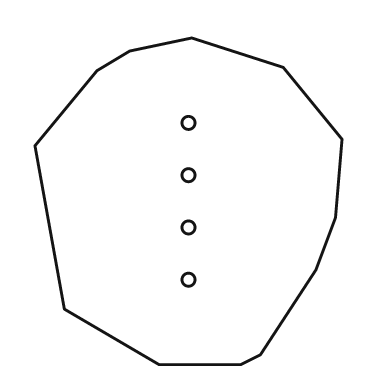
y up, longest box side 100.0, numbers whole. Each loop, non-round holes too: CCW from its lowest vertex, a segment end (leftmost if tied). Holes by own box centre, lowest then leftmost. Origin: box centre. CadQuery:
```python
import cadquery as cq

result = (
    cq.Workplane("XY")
    .moveTo(-9.0, -50.0)
    .lineTo(16.0, -50.0)
    .lineTo(22.0, -47.0)
    .lineTo(39.0, -21.0)
    .lineTo(45.0, -5.0)
    .lineTo(47.0, 19.0)
    .lineTo(29.0, 41.0)
    .lineTo(1.0, 50.0)
    .lineTo(-18.0, 46.0)
    .lineTo(-28.0, 40.0)
    .lineTo(-47.0, 17.0)
    .lineTo(-38.0, -33.0)
    .close()
    .moveTo(0.0, -24.0)
    .circle(2.0)
    .moveTo(0.0, -8.0)
    .circle(2.0)
    .moveTo(0.0, 8.0)
    .circle(2.0)
    .moveTo(0.0, 24.0)
    .circle(2.0)
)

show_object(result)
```